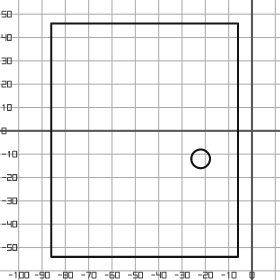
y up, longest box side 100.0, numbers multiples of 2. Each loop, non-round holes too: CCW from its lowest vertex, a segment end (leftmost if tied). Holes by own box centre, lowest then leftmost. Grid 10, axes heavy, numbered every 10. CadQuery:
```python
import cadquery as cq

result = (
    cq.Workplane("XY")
    .moveTo(-86.0, -54.0)
    .lineTo(-6.0, -54.0)
    .lineTo(-6.0, 46.0)
    .lineTo(-86.0, 46.0)
    .close()
    .moveTo(-22.0, -12.0)
    .circle(4.0)
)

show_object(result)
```